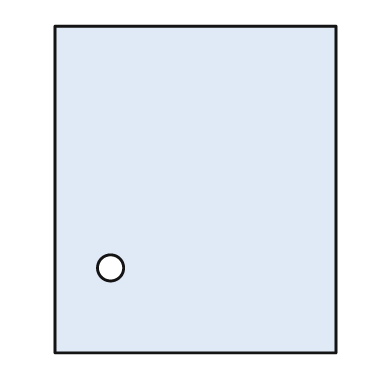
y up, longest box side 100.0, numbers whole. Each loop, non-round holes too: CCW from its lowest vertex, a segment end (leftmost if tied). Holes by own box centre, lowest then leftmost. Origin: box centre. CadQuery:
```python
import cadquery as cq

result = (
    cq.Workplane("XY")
    .moveTo(-43.0, -50.0)
    .lineTo(43.0, -50.0)
    .lineTo(43.0, 50.0)
    .lineTo(-43.0, 50.0)
    .close()
    .moveTo(-26.0, -24.0)
    .circle(4.0)
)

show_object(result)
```